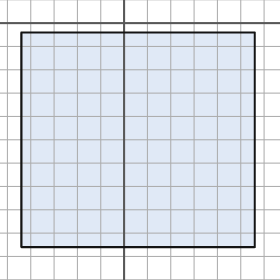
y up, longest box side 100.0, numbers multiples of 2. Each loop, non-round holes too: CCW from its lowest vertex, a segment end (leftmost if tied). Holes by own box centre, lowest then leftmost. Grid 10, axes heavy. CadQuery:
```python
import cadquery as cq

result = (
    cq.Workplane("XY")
    .moveTo(-44.0, -96.0)
    .lineTo(56.0, -96.0)
    .lineTo(56.0, -4.0)
    .lineTo(-44.0, -4.0)
    .close()
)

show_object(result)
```